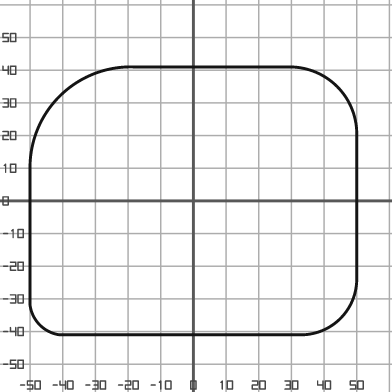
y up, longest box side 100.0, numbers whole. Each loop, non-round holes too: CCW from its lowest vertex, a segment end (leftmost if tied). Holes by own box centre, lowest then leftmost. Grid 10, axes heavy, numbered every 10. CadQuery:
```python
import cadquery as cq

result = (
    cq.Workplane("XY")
    .moveTo(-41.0, -41.0)
    .lineTo(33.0, -41.0)
    .threePointArc((45.0, -36.0), (50.0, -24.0))
    .lineTo(50.0, 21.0)
    .threePointArc((44.0, 35.0), (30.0, 41.0))
    .lineTo(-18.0, 41.0)
    .threePointArc((-41.0, 32.0), (-50.0, 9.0))
    .lineTo(-50.0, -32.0)
    .threePointArc((-47.0, -38.0), (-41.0, -41.0))
    .close()
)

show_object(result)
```